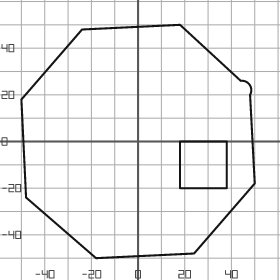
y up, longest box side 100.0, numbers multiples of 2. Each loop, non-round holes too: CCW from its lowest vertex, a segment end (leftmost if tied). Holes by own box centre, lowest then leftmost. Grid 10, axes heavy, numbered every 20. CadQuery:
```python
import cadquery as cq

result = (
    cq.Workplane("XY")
    .moveTo(-18.0, -50.0)
    .lineTo(24.0, -48.0)
    .lineTo(50.0, -18.0)
    .lineTo(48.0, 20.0)
    .threePointArc((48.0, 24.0), (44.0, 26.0))
    .lineTo(18.0, 50.0)
    .lineTo(-24.0, 48.0)
    .lineTo(-50.0, 18.0)
    .lineTo(-48.0, -24.0)
    .close()
    .moveTo(18.0, -20.0)
    .lineTo(38.0, -20.0)
    .lineTo(38.0, 0.0)
    .lineTo(18.0, 0.0)
    .close()
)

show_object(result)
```